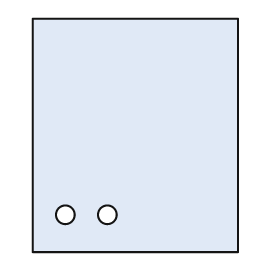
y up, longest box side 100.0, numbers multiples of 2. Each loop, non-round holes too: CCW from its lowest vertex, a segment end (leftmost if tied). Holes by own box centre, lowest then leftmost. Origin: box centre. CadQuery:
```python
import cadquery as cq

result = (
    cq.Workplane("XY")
    .moveTo(-44.0, -50.0)
    .lineTo(44.0, -50.0)
    .lineTo(44.0, 50.0)
    .lineTo(-44.0, 50.0)
    .close()
    .moveTo(-30.0, -34.0)
    .circle(4.0)
    .moveTo(-12.0, -34.0)
    .circle(4.0)
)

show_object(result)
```